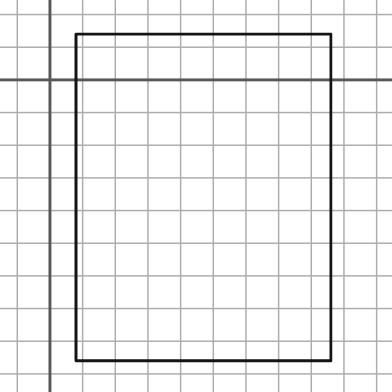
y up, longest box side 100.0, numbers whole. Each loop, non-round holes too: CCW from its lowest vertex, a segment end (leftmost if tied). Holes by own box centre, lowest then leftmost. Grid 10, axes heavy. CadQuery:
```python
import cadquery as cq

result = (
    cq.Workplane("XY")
    .moveTo(8.0, -86.0)
    .lineTo(86.0, -86.0)
    .lineTo(86.0, 14.0)
    .lineTo(8.0, 14.0)
    .close()
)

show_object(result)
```